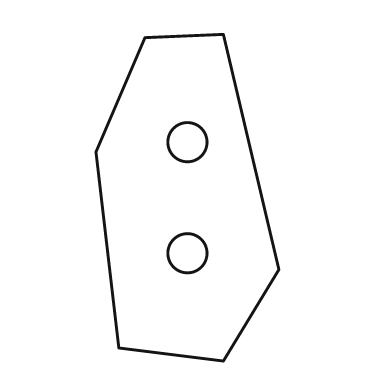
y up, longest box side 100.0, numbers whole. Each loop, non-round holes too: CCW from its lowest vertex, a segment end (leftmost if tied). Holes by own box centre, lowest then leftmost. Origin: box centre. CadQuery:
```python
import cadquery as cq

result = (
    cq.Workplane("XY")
    .moveTo(11.0, -50.0)
    .lineTo(28.0, -22.0)
    .lineTo(11.0, 50.0)
    .lineTo(-13.0, 49.0)
    .lineTo(-28.0, 14.0)
    .lineTo(-21.0, -46.0)
    .close()
    .moveTo(0.0, -17.0)
    .circle(6.0)
    .moveTo(0.0, 17.0)
    .circle(6.0)
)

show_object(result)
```